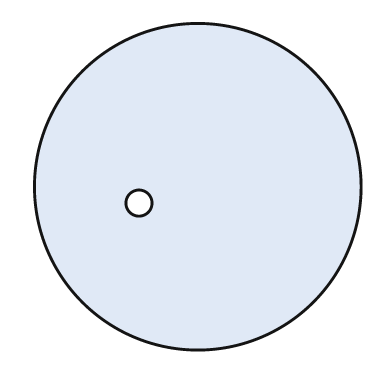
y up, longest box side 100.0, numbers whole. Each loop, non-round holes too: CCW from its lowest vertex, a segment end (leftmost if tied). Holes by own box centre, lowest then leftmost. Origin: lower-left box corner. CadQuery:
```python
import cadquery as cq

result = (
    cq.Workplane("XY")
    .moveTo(50.0, 50.0)
    .circle(50.0)
    .moveTo(32.0, 45.0)
    .circle(4.0)
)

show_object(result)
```